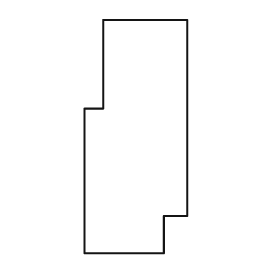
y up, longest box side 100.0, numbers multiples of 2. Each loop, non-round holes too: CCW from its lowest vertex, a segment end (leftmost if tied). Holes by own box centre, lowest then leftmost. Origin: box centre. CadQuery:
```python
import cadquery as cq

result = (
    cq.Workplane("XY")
    .moveTo(-22.0, -50.0)
    .lineTo(12.0, -50.0)
    .lineTo(12.0, -34.0)
    .lineTo(22.0, -34.0)
    .lineTo(22.0, 50.0)
    .lineTo(-14.0, 50.0)
    .lineTo(-14.0, 12.0)
    .lineTo(-22.0, 12.0)
    .close()
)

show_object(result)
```